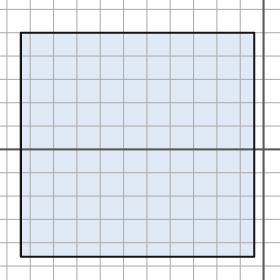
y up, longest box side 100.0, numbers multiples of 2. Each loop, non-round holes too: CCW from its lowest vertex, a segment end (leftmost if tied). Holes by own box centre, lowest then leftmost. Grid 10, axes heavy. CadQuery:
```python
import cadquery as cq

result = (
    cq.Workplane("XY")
    .moveTo(-104.0, -46.0)
    .lineTo(-4.0, -46.0)
    .lineTo(-4.0, 50.0)
    .lineTo(-104.0, 50.0)
    .close()
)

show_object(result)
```